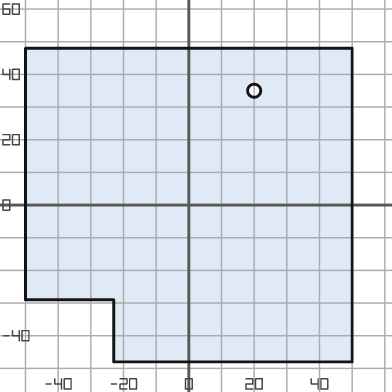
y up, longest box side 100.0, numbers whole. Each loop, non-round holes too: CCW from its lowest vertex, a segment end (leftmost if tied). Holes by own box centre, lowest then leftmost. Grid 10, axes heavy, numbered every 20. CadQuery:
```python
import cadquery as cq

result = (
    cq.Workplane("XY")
    .moveTo(-23.0, -48.0)
    .lineTo(50.0, -48.0)
    .lineTo(50.0, 48.0)
    .lineTo(-50.0, 48.0)
    .lineTo(-50.0, -29.0)
    .lineTo(-23.0, -29.0)
    .close()
    .moveTo(20.0, 35.0)
    .circle(2.0)
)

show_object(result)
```